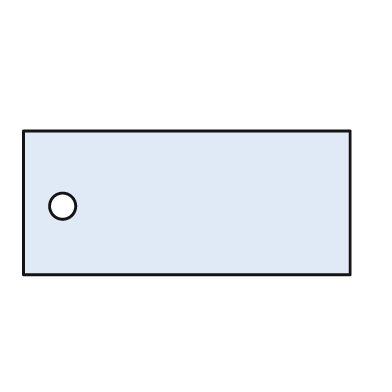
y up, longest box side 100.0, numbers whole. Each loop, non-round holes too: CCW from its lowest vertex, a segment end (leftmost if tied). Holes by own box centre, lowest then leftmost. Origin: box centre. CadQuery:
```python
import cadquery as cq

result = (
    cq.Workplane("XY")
    .moveTo(-50.0, -22.0)
    .lineTo(50.0, -22.0)
    .lineTo(50.0, 22.0)
    .lineTo(-50.0, 22.0)
    .close()
    .moveTo(-38.0, -1.0)
    .circle(4.0)
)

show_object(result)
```